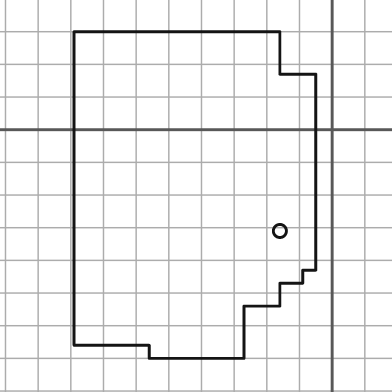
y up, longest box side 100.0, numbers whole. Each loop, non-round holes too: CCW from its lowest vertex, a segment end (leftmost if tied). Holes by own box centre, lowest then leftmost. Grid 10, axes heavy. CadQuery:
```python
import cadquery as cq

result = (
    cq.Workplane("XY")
    .moveTo(-56.0, -70.0)
    .lineTo(-27.0, -70.0)
    .lineTo(-27.0, -54.0)
    .lineTo(-16.0, -54.0)
    .lineTo(-16.0, -47.0)
    .lineTo(-9.0, -47.0)
    .lineTo(-9.0, -43.0)
    .lineTo(-5.0, -43.0)
    .lineTo(-5.0, 17.0)
    .lineTo(-16.0, 17.0)
    .lineTo(-16.0, 30.0)
    .lineTo(-79.0, 30.0)
    .lineTo(-79.0, -66.0)
    .lineTo(-56.0, -66.0)
    .close()
    .moveTo(-16.0, -31.0)
    .circle(2.0)
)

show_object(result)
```